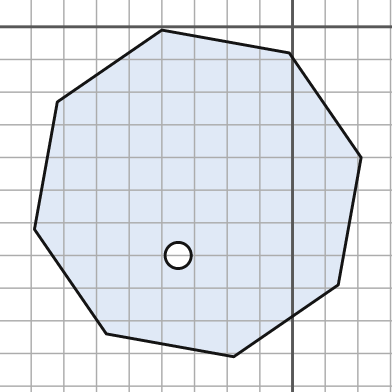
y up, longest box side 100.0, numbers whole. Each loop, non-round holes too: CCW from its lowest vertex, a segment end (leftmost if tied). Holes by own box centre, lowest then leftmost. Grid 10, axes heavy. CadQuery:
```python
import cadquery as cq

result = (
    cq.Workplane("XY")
    .moveTo(-18.0, -101.0)
    .lineTo(14.0, -79.0)
    .lineTo(21.0, -40.0)
    .lineTo(-1.0, -8.0)
    .lineTo(-40.0, -1.0)
    .lineTo(-72.0, -23.0)
    .lineTo(-79.0, -62.0)
    .lineTo(-57.0, -94.0)
    .close()
    .moveTo(-35.0, -70.0)
    .circle(4.0)
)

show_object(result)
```